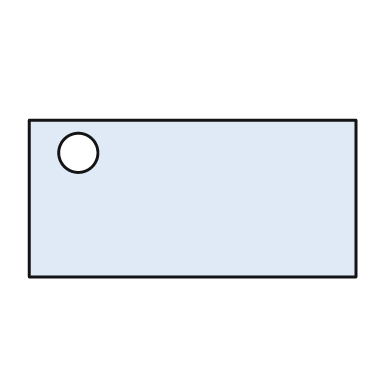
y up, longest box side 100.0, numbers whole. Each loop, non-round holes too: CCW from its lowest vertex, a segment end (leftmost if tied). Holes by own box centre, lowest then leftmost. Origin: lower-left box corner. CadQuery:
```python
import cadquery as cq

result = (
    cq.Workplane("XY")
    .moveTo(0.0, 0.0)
    .lineTo(100.0, 0.0)
    .lineTo(100.0, 48.0)
    .lineTo(0.0, 48.0)
    .close()
    .moveTo(15.0, 38.0)
    .circle(6.0)
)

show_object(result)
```